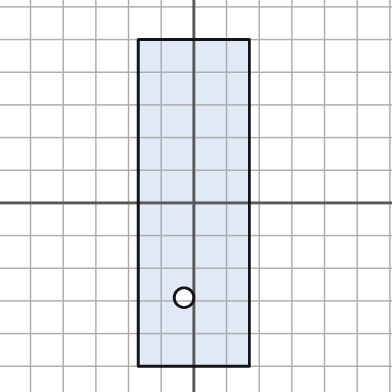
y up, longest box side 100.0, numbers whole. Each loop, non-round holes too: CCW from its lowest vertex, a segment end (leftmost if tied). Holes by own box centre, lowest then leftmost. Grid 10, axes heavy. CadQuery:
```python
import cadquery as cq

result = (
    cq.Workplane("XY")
    .moveTo(-17.0, -50.0)
    .lineTo(17.0, -50.0)
    .lineTo(17.0, 50.0)
    .lineTo(-17.0, 50.0)
    .close()
    .moveTo(-3.0, -29.0)
    .circle(3.0)
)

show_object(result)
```